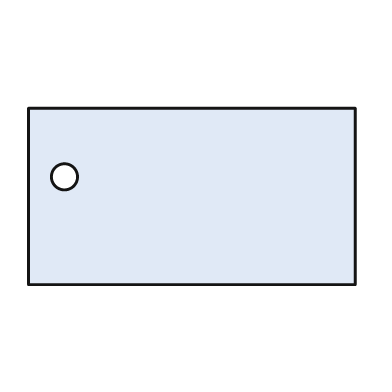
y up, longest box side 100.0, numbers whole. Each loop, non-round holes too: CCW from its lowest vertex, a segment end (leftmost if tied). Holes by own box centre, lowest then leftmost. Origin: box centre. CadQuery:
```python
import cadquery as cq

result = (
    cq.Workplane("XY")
    .moveTo(-50.0, -27.0)
    .lineTo(50.0, -27.0)
    .lineTo(50.0, 27.0)
    .lineTo(-50.0, 27.0)
    .close()
    .moveTo(-39.0, 6.0)
    .circle(4.0)
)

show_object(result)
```